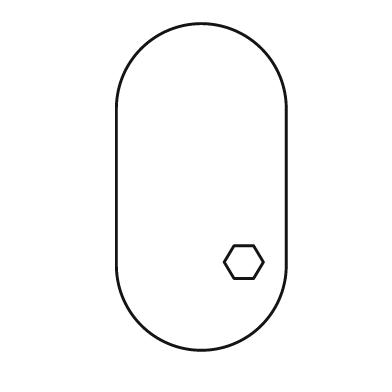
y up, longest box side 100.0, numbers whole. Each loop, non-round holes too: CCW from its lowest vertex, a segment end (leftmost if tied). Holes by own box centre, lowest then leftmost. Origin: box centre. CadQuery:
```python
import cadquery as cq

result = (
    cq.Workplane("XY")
    .moveTo(-26.0, -24.0)
    .threePointArc((0.0, -50.0), (26.0, -24.0))
    .lineTo(26.0, 24.0)
    .threePointArc((0.0, 50.0), (-26.0, 24.0))
    .close()
    .moveTo(10.0, -28.0)
    .lineTo(16.0, -28.0)
    .lineTo(19.0, -23.0)
    .lineTo(16.0, -18.0)
    .lineTo(10.0, -18.0)
    .lineTo(7.0, -23.0)
    .close()
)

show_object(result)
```